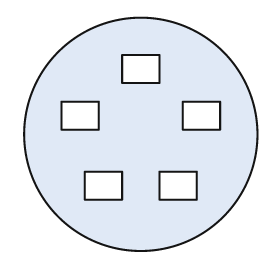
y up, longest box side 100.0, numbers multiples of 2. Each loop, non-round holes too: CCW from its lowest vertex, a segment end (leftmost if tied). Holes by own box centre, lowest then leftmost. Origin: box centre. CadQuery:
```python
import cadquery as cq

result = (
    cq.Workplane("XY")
    .moveTo(0.0, 0.0)
    .circle(50.0)
    .moveTo(-24.0, -28.0)
    .lineTo(-8.0, -28.0)
    .lineTo(-8.0, -16.0)
    .lineTo(-24.0, -16.0)
    .close()
    .moveTo(8.0, -28.0)
    .lineTo(24.0, -28.0)
    .lineTo(24.0, -16.0)
    .lineTo(8.0, -16.0)
    .close()
    .moveTo(-34.0, 2.0)
    .lineTo(-18.0, 2.0)
    .lineTo(-18.0, 14.0)
    .lineTo(-34.0, 14.0)
    .close()
    .moveTo(18.0, 2.0)
    .lineTo(34.0, 2.0)
    .lineTo(34.0, 14.0)
    .lineTo(18.0, 14.0)
    .close()
    .moveTo(-8.0, 22.0)
    .lineTo(8.0, 22.0)
    .lineTo(8.0, 34.0)
    .lineTo(-8.0, 34.0)
    .close()
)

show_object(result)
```